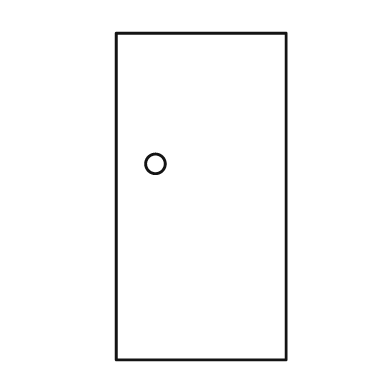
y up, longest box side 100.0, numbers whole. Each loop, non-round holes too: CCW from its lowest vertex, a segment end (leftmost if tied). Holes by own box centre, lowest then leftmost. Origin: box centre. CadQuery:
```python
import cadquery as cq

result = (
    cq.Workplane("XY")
    .moveTo(-26.0, -50.0)
    .lineTo(26.0, -50.0)
    .lineTo(26.0, 50.0)
    .lineTo(-26.0, 50.0)
    .close()
    .moveTo(-14.0, 10.0)
    .circle(3.0)
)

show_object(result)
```